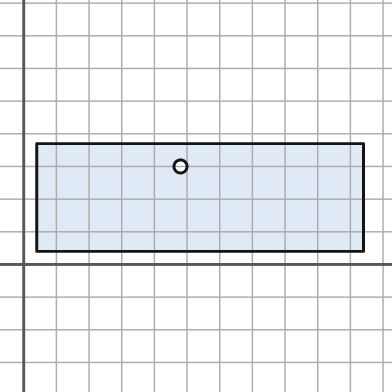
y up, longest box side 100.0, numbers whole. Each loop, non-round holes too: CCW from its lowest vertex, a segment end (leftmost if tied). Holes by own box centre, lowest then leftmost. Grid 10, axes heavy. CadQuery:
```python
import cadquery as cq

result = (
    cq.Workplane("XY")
    .moveTo(4.0, 4.0)
    .lineTo(104.0, 4.0)
    .lineTo(104.0, 37.0)
    .lineTo(4.0, 37.0)
    .close()
    .moveTo(48.0, 30.0)
    .circle(2.0)
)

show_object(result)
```